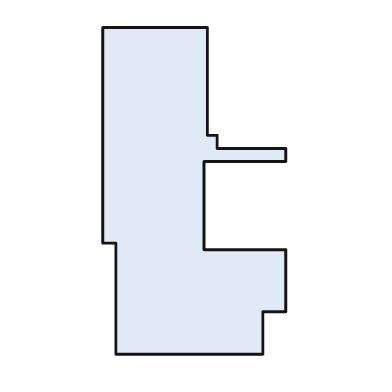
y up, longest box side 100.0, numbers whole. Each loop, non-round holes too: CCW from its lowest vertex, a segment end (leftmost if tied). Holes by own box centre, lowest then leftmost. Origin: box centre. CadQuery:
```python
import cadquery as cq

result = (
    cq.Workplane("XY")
    .moveTo(-24.0, -50.0)
    .lineTo(21.0, -50.0)
    .lineTo(21.0, -37.0)
    .lineTo(28.0, -37.0)
    .lineTo(28.0, -18.0)
    .lineTo(3.0, -18.0)
    .lineTo(3.0, 9.0)
    .lineTo(28.0, 9.0)
    .lineTo(28.0, 13.0)
    .lineTo(7.0, 13.0)
    .lineTo(7.0, 17.0)
    .lineTo(4.0, 17.0)
    .lineTo(4.0, 50.0)
    .lineTo(-28.0, 50.0)
    .lineTo(-28.0, -16.0)
    .lineTo(-24.0, -16.0)
    .close()
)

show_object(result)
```